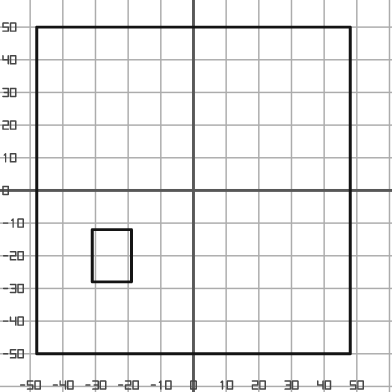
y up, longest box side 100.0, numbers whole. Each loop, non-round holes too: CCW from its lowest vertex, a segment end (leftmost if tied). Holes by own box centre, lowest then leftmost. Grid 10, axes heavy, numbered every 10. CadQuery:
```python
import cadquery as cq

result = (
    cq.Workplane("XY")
    .moveTo(-48.0, -50.0)
    .lineTo(48.0, -50.0)
    .lineTo(48.0, 50.0)
    .lineTo(-48.0, 50.0)
    .close()
    .moveTo(-31.0, -28.0)
    .lineTo(-19.0, -28.0)
    .lineTo(-19.0, -12.0)
    .lineTo(-31.0, -12.0)
    .close()
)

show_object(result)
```